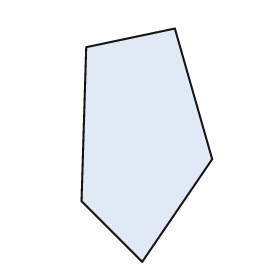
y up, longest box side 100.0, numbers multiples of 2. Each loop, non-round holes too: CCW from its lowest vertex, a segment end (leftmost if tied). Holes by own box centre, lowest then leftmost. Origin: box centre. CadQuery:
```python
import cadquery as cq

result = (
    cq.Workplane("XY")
    .moveTo(-2.0, -50.0)
    .lineTo(28.0, -6.0)
    .lineTo(12.0, 50.0)
    .lineTo(-26.0, 42.0)
    .lineTo(-28.0, -24.0)
    .close()
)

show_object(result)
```